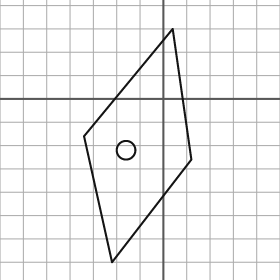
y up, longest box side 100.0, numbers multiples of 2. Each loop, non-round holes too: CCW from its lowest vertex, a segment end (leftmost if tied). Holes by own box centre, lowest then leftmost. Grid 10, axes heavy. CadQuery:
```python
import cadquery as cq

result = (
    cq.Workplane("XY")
    .moveTo(-22.0, -70.0)
    .lineTo(12.0, -26.0)
    .lineTo(4.0, 30.0)
    .lineTo(-34.0, -16.0)
    .close()
    .moveTo(-16.0, -22.0)
    .circle(4.0)
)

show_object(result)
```